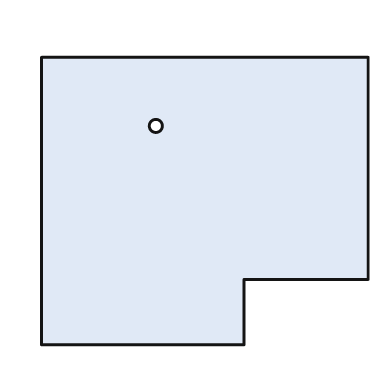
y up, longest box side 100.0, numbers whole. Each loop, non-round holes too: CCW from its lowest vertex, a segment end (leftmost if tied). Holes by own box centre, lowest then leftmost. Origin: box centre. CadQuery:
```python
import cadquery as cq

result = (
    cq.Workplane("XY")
    .moveTo(-50.0, -44.0)
    .lineTo(12.0, -44.0)
    .lineTo(12.0, -24.0)
    .lineTo(50.0, -24.0)
    .lineTo(50.0, 44.0)
    .lineTo(-50.0, 44.0)
    .close()
    .moveTo(-15.0, 23.0)
    .circle(2.0)
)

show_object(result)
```